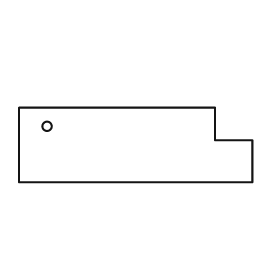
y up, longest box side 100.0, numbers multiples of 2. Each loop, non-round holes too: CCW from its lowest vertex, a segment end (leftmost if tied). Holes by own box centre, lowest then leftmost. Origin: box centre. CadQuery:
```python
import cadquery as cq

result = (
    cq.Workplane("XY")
    .moveTo(-50.0, -16.0)
    .lineTo(50.0, -16.0)
    .lineTo(50.0, 2.0)
    .lineTo(34.0, 2.0)
    .lineTo(34.0, 16.0)
    .lineTo(-50.0, 16.0)
    .close()
    .moveTo(-38.0, 8.0)
    .circle(2.0)
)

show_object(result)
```